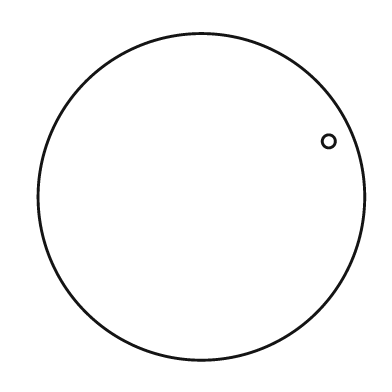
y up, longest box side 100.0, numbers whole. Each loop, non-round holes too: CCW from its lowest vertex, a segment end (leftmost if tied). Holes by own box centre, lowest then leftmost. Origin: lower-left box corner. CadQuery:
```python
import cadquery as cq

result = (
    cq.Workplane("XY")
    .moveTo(50.0, 50.0)
    .circle(50.0)
    .moveTo(89.0, 67.0)
    .circle(2.0)
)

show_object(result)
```